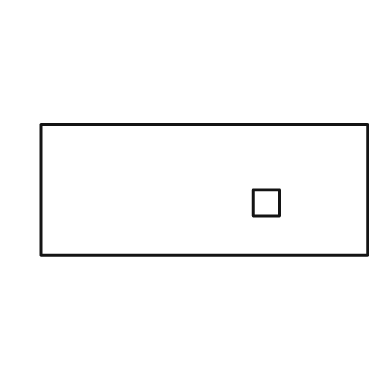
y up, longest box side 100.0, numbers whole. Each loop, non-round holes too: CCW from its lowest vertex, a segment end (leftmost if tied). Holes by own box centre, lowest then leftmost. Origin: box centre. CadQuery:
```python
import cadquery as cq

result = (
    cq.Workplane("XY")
    .moveTo(-50.0, -20.0)
    .lineTo(50.0, -20.0)
    .lineTo(50.0, 20.0)
    .lineTo(-50.0, 20.0)
    .close()
    .moveTo(15.0, -8.0)
    .lineTo(23.0, -8.0)
    .lineTo(23.0, 0.0)
    .lineTo(15.0, 0.0)
    .close()
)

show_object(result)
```